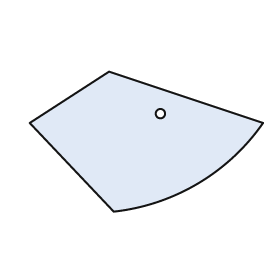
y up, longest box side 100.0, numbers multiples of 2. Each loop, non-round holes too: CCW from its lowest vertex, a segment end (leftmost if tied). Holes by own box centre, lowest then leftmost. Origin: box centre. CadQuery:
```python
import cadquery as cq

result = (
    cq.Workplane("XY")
    .moveTo(-14.0, -30.0)
    .threePointArc((22.0, -18.0), (50.0, 8.0))
    .lineTo(-16.0, 30.0)
    .lineTo(-50.0, 8.0)
    .close()
    .moveTo(6.0, 12.0)
    .circle(2.0)
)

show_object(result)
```